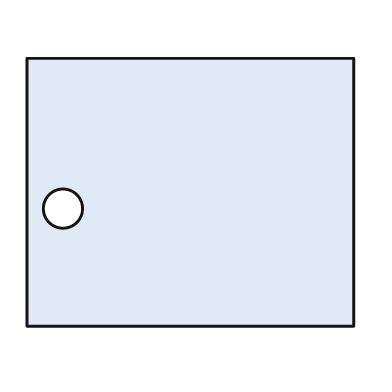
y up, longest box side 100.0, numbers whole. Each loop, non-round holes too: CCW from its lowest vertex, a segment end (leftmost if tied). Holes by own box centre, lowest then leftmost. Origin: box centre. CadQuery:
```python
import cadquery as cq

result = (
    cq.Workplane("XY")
    .moveTo(-50.0, -41.0)
    .lineTo(50.0, -41.0)
    .lineTo(50.0, 41.0)
    .lineTo(-50.0, 41.0)
    .close()
    .moveTo(-39.0, -5.0)
    .circle(6.0)
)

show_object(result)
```